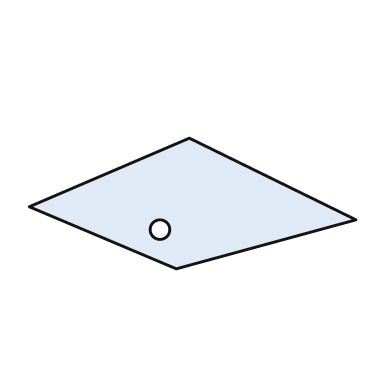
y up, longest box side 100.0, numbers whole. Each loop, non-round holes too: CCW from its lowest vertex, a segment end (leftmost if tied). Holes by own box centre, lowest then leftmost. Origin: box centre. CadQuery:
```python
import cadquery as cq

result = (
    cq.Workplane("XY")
    .moveTo(-5.0, -20.0)
    .lineTo(50.0, -5.0)
    .lineTo(-1.0, 20.0)
    .lineTo(-50.0, -1.0)
    .close()
    .moveTo(-10.0, -8.0)
    .circle(3.0)
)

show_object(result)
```